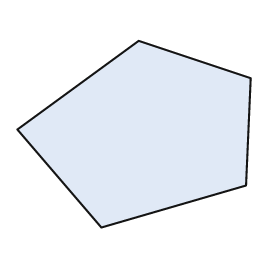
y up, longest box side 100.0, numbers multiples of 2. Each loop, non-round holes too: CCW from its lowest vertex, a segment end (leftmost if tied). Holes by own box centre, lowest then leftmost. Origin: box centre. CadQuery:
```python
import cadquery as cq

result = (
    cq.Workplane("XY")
    .moveTo(-14.0, -40.0)
    .lineTo(48.0, -22.0)
    .lineTo(50.0, 24.0)
    .lineTo(2.0, 40.0)
    .lineTo(-50.0, 2.0)
    .close()
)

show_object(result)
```